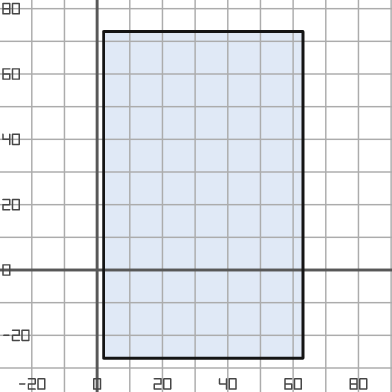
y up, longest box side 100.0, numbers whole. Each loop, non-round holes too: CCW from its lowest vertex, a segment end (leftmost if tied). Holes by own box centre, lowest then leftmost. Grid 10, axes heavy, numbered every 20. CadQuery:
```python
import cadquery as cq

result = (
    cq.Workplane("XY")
    .moveTo(2.0, -27.0)
    .lineTo(63.0, -27.0)
    .lineTo(63.0, 73.0)
    .lineTo(2.0, 73.0)
    .close()
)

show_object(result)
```